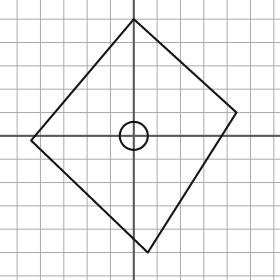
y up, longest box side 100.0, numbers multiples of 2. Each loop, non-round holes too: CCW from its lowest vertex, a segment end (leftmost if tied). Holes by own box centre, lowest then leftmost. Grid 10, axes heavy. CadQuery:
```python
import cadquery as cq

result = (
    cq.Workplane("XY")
    .moveTo(6.0, -50.0)
    .lineTo(44.0, 10.0)
    .lineTo(0.0, 50.0)
    .lineTo(-44.0, -2.0)
    .close()
    .moveTo(0.0, 0.0)
    .circle(6.0)
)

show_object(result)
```